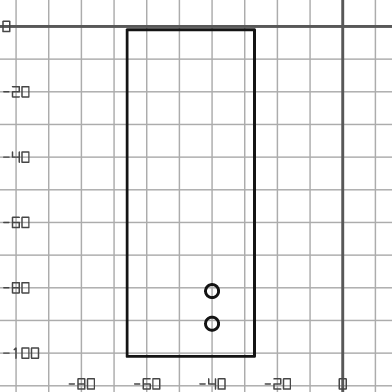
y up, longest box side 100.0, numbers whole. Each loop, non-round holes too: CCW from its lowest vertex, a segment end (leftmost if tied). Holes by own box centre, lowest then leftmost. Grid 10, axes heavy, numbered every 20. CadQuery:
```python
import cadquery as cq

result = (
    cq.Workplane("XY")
    .moveTo(-66.0, -101.0)
    .lineTo(-27.0, -101.0)
    .lineTo(-27.0, -1.0)
    .lineTo(-66.0, -1.0)
    .close()
    .moveTo(-40.0, -91.0)
    .circle(2.0)
    .moveTo(-40.0, -81.0)
    .circle(2.0)
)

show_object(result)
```